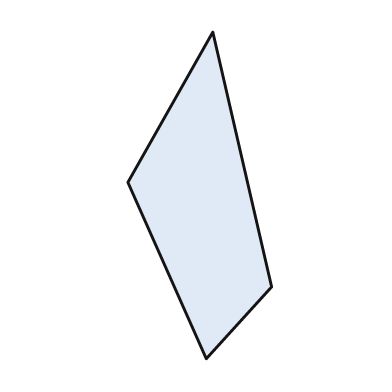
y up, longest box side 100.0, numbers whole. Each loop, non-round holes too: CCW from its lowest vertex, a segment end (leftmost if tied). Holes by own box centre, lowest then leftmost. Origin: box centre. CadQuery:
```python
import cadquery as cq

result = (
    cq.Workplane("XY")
    .moveTo(2.0, -50.0)
    .lineTo(22.0, -28.0)
    .lineTo(4.0, 50.0)
    .lineTo(-22.0, 4.0)
    .close()
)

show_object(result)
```